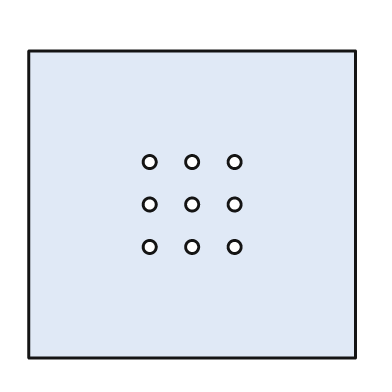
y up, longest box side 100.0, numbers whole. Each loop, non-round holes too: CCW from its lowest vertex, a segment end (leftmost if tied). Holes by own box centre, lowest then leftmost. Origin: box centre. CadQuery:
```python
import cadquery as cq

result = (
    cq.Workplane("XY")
    .moveTo(-50.0, -47.0)
    .lineTo(50.0, -47.0)
    .lineTo(50.0, 47.0)
    .lineTo(-50.0, 47.0)
    .close()
    .moveTo(-13.0, -13.0)
    .circle(2.0)
    .moveTo(0.0, -13.0)
    .circle(2.0)
    .moveTo(13.0, -13.0)
    .circle(2.0)
    .moveTo(-13.0, 0.0)
    .circle(2.0)
    .moveTo(0.0, 0.0)
    .circle(2.0)
    .moveTo(13.0, 0.0)
    .circle(2.0)
    .moveTo(-13.0, 13.0)
    .circle(2.0)
    .moveTo(0.0, 13.0)
    .circle(2.0)
    .moveTo(13.0, 13.0)
    .circle(2.0)
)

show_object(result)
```